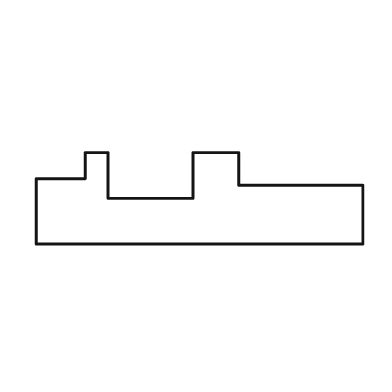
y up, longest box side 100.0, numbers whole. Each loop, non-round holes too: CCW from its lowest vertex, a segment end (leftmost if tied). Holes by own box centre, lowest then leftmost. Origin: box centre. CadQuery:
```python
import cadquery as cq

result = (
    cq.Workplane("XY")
    .moveTo(-50.0, -14.0)
    .lineTo(50.0, -14.0)
    .lineTo(50.0, 4.0)
    .lineTo(12.0, 4.0)
    .lineTo(12.0, 14.0)
    .lineTo(-2.0, 14.0)
    .lineTo(-2.0, 0.0)
    .lineTo(-28.0, 0.0)
    .lineTo(-28.0, 14.0)
    .lineTo(-35.0, 14.0)
    .lineTo(-35.0, 6.0)
    .lineTo(-50.0, 6.0)
    .close()
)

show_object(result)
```